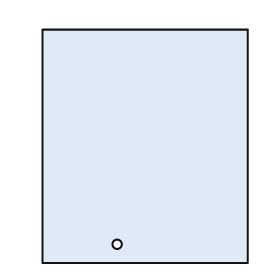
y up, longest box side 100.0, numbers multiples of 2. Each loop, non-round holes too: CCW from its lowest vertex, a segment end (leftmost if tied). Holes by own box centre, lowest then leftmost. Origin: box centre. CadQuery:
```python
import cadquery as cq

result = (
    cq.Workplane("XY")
    .moveTo(-44.0, -50.0)
    .lineTo(44.0, -50.0)
    .lineTo(44.0, 50.0)
    .lineTo(-44.0, 50.0)
    .close()
    .moveTo(-12.0, -42.0)
    .circle(2.0)
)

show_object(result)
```